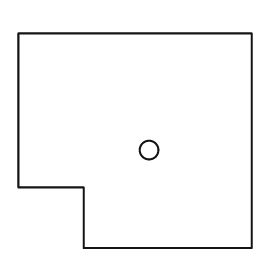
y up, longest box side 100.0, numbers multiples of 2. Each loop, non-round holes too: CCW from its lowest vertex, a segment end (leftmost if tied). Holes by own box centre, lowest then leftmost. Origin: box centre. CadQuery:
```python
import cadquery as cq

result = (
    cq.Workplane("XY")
    .moveTo(-22.0, -46.0)
    .lineTo(50.0, -46.0)
    .lineTo(50.0, 46.0)
    .lineTo(-50.0, 46.0)
    .lineTo(-50.0, -20.0)
    .lineTo(-22.0, -20.0)
    .close()
    .moveTo(6.0, -4.0)
    .circle(4.0)
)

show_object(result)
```